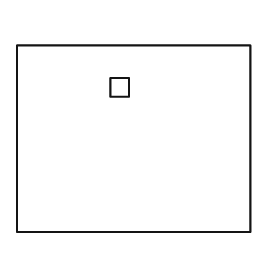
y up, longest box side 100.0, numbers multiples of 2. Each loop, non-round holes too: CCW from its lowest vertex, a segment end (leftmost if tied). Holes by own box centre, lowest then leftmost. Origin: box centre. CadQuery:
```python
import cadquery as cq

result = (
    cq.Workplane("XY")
    .moveTo(-50.0, -40.0)
    .lineTo(50.0, -40.0)
    .lineTo(50.0, 40.0)
    .lineTo(-50.0, 40.0)
    .close()
    .moveTo(-10.0, 18.0)
    .lineTo(-2.0, 18.0)
    .lineTo(-2.0, 26.0)
    .lineTo(-10.0, 26.0)
    .close()
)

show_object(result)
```